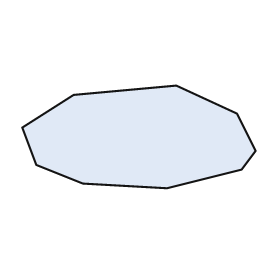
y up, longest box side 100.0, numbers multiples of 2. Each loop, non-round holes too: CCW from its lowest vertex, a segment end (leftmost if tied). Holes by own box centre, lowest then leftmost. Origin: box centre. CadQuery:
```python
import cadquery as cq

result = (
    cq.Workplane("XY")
    .moveTo(12.0, -22.0)
    .lineTo(44.0, -14.0)
    .lineTo(50.0, -6.0)
    .lineTo(42.0, 10.0)
    .lineTo(16.0, 22.0)
    .lineTo(-28.0, 18.0)
    .lineTo(-50.0, 4.0)
    .lineTo(-44.0, -12.0)
    .lineTo(-24.0, -20.0)
    .close()
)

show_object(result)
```